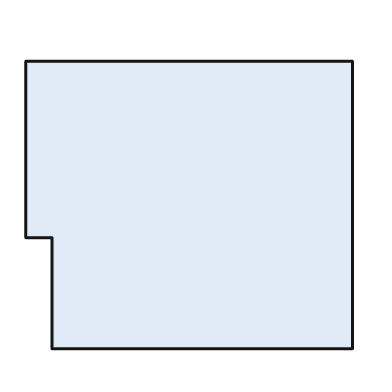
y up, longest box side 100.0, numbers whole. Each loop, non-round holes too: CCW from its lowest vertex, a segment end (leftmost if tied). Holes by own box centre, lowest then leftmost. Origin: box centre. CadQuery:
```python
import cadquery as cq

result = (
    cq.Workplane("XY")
    .moveTo(-42.0, -44.0)
    .lineTo(50.0, -44.0)
    .lineTo(50.0, 44.0)
    .lineTo(-50.0, 44.0)
    .lineTo(-50.0, -10.0)
    .lineTo(-42.0, -10.0)
    .close()
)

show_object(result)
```